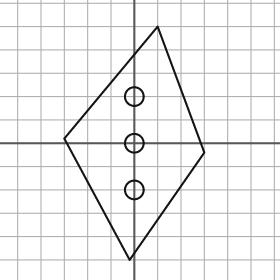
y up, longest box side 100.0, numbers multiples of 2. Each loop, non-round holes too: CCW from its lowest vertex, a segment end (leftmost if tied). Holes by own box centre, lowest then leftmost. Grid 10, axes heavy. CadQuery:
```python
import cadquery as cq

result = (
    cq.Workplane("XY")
    .moveTo(-2.0, -50.0)
    .lineTo(30.0, -4.0)
    .lineTo(10.0, 50.0)
    .lineTo(-30.0, 2.0)
    .close()
    .moveTo(0.0, -20.0)
    .circle(4.0)
    .moveTo(0.0, 0.0)
    .circle(4.0)
    .moveTo(0.0, 20.0)
    .circle(4.0)
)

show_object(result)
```